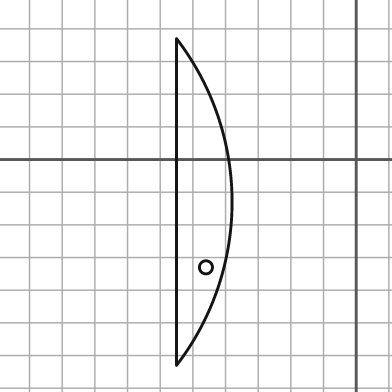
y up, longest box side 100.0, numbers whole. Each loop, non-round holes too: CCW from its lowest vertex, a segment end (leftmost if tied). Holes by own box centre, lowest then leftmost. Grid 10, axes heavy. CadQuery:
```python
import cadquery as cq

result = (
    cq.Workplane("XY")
    .moveTo(-55.0, -63.0)
    .threePointArc((-38.0, -13.0), (-55.0, 37.0))
    .close()
    .moveTo(-46.0, -33.0)
    .circle(2.0)
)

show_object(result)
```